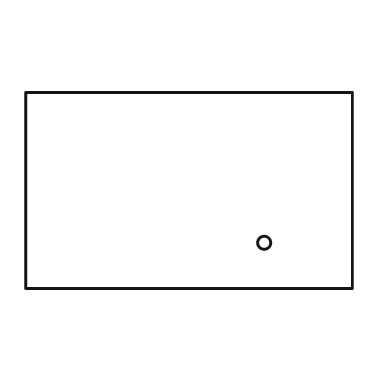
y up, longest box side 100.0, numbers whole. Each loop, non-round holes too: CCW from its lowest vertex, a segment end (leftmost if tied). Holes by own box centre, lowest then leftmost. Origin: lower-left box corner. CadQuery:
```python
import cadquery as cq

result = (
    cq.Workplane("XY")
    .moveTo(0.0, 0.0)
    .lineTo(100.0, 0.0)
    .lineTo(100.0, 60.0)
    .lineTo(0.0, 60.0)
    .close()
    .moveTo(73.0, 14.0)
    .circle(2.0)
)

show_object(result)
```